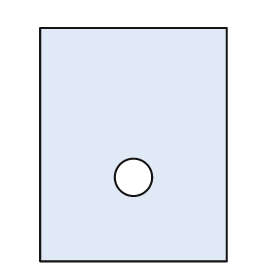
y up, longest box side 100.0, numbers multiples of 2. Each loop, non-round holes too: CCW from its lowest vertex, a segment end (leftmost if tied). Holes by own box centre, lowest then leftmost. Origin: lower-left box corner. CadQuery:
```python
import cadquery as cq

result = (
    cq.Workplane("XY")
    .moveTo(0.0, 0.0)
    .lineTo(80.0, 0.0)
    .lineTo(80.0, 100.0)
    .lineTo(0.0, 100.0)
    .close()
    .moveTo(40.0, 36.0)
    .circle(8.0)
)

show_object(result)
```